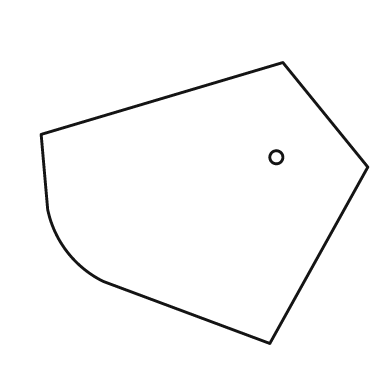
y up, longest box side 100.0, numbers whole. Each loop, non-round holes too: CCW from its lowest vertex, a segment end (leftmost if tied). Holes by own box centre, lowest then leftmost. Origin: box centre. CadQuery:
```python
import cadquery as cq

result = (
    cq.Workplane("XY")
    .moveTo(20.0, -43.0)
    .lineTo(50.0, 11.0)
    .lineTo(24.0, 43.0)
    .lineTo(-50.0, 21.0)
    .lineTo(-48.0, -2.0)
    .threePointArc((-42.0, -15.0), (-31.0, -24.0))
    .close()
    .moveTo(22.0, 14.0)
    .circle(2.0)
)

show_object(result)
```